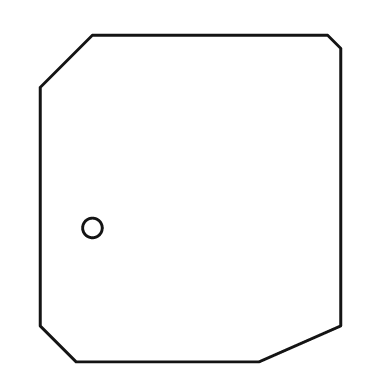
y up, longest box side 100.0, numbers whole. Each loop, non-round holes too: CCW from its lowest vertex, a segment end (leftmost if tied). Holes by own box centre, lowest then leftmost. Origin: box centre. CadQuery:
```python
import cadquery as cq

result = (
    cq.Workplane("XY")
    .moveTo(-35.0, -50.0)
    .lineTo(21.0, -50.0)
    .lineTo(46.0, -39.0)
    .lineTo(46.0, 46.0)
    .lineTo(42.0, 50.0)
    .lineTo(-30.0, 50.0)
    .lineTo(-46.0, 34.0)
    .lineTo(-46.0, -39.0)
    .close()
    .moveTo(-30.0, -9.0)
    .circle(3.0)
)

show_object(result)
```